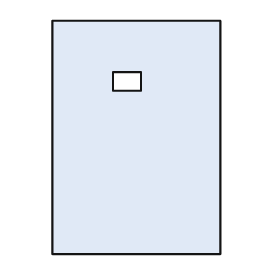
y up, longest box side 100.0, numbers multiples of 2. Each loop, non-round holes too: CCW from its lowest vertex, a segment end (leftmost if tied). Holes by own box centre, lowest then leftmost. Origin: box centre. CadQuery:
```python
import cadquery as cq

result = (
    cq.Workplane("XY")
    .moveTo(-36.0, -50.0)
    .lineTo(36.0, -50.0)
    .lineTo(36.0, 50.0)
    .lineTo(-36.0, 50.0)
    .close()
    .moveTo(-10.0, 20.0)
    .lineTo(2.0, 20.0)
    .lineTo(2.0, 28.0)
    .lineTo(-10.0, 28.0)
    .close()
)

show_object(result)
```